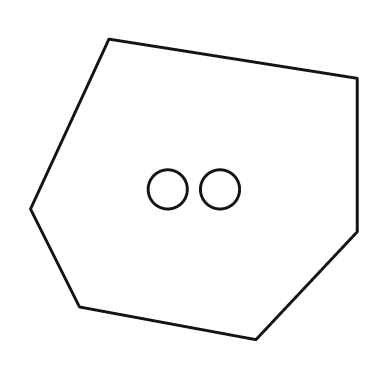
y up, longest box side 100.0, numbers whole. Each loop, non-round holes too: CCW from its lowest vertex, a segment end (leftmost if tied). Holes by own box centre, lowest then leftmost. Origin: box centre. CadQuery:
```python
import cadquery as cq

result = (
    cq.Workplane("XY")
    .moveTo(19.0, -46.0)
    .lineTo(50.0, -13.0)
    .lineTo(50.0, 34.0)
    .lineTo(-26.0, 46.0)
    .lineTo(-50.0, -6.0)
    .lineTo(-35.0, -36.0)
    .close()
    .moveTo(-8.0, 0.0)
    .circle(6.0)
    .moveTo(8.0, 0.0)
    .circle(6.0)
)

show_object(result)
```